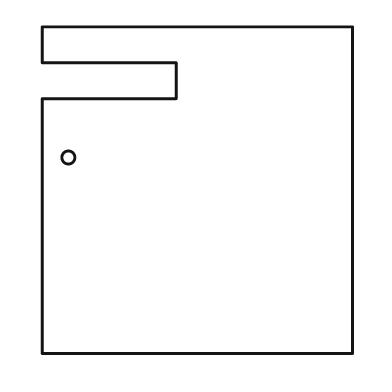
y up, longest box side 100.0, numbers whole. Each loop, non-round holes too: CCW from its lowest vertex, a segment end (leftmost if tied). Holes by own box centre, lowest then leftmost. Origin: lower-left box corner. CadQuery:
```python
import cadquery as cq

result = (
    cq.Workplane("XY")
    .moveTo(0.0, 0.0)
    .lineTo(95.0, 0.0)
    .lineTo(95.0, 100.0)
    .lineTo(0.0, 100.0)
    .lineTo(0.0, 89.0)
    .lineTo(41.0, 89.0)
    .lineTo(41.0, 78.0)
    .lineTo(0.0, 78.0)
    .close()
    .moveTo(8.0, 60.0)
    .circle(2.0)
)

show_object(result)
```